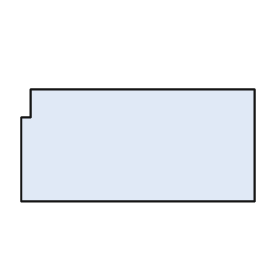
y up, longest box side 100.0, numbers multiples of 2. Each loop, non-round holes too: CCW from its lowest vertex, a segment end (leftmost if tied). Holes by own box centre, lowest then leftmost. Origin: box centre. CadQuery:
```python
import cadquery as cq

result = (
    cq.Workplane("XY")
    .moveTo(-50.0, -24.0)
    .lineTo(50.0, -24.0)
    .lineTo(50.0, 24.0)
    .lineTo(-46.0, 24.0)
    .lineTo(-46.0, 12.0)
    .lineTo(-50.0, 12.0)
    .close()
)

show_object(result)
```